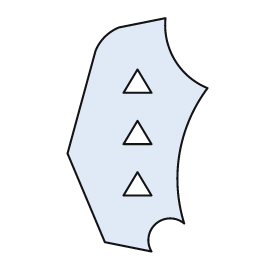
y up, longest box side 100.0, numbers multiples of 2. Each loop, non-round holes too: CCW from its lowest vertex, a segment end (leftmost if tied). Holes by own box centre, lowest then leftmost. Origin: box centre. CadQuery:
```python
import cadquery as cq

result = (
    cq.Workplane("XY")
    .moveTo(6.0, -50.0)
    .threePointArc((8.0, -38.0), (20.0, -38.0))
    .threePointArc((18.0, -8.0), (30.0, 20.0))
    .threePointArc((16.0, 32.0), (12.0, 50.0))
    .lineTo(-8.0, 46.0)
    .threePointArc((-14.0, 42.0), (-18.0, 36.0))
    .lineTo(-30.0, -8.0)
    .lineTo(-14.0, -46.0)
    .close()
    .moveTo(-6.0, -26.0)
    .lineTo(6.0, -26.0)
    .lineTo(0.0, -16.0)
    .close()
    .moveTo(-6.0, -4.0)
    .lineTo(6.0, -4.0)
    .lineTo(0.0, 6.0)
    .close()
    .moveTo(-6.0, 18.0)
    .lineTo(6.0, 18.0)
    .lineTo(0.0, 28.0)
    .close()
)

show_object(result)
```